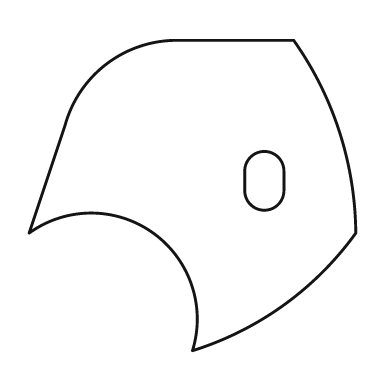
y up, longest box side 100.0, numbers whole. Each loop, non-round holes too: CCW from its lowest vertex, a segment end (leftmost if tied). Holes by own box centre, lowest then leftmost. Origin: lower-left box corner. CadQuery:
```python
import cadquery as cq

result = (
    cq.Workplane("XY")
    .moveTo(50.0, 0.0)
    .threePointArc((78.0, 14.0), (100.0, 36.0))
    .threePointArc((95.0, 67.0), (81.0, 95.0))
    .lineTo(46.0, 95.0)
    .threePointArc((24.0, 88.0), (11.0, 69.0))
    .lineTo(0.0, 36.0)
    .threePointArc((38.0, 36.0), (50.0, 0.0))
    .close()
    .moveTo(66.0, 49.0)
    .threePointArc((72.0, 43.0), (78.0, 49.0))
    .lineTo(78.0, 55.0)
    .threePointArc((72.0, 61.0), (66.0, 55.0))
    .close()
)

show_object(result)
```